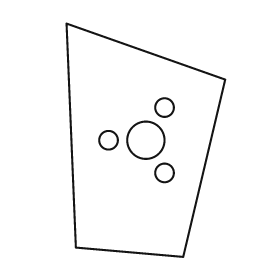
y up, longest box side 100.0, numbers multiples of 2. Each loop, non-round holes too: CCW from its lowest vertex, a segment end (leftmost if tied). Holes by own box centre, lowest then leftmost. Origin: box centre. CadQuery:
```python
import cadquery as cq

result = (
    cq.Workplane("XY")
    .moveTo(16.0, -50.0)
    .lineTo(34.0, 26.0)
    .lineTo(-34.0, 50.0)
    .lineTo(-30.0, -46.0)
    .close()
    .moveTo(8.0, -14.0)
    .circle(4.0)
    .moveTo(-16.0, 0.0)
    .circle(4.0)
    .moveTo(0.0, 0.0)
    .circle(8.0)
    .moveTo(8.0, 14.0)
    .circle(4.0)
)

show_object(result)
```